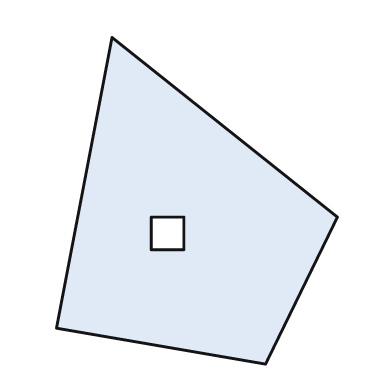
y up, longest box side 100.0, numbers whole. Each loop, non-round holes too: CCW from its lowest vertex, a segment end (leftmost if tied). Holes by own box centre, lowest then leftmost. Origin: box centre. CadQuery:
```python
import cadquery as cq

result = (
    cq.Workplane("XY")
    .moveTo(21.0, -50.0)
    .lineTo(43.0, -5.0)
    .lineTo(-26.0, 50.0)
    .lineTo(-43.0, -39.0)
    .close()
    .moveTo(-14.0, -15.0)
    .lineTo(-4.0, -15.0)
    .lineTo(-4.0, -5.0)
    .lineTo(-14.0, -5.0)
    .close()
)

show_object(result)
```